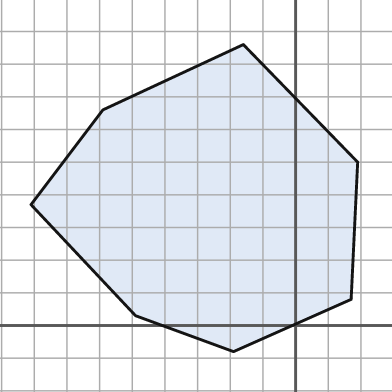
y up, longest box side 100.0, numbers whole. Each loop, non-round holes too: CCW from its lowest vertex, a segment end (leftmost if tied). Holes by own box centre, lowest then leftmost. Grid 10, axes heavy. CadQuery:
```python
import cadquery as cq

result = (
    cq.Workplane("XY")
    .moveTo(-19.0, -8.0)
    .lineTo(17.0, 8.0)
    .lineTo(19.0, 50.0)
    .lineTo(-16.0, 86.0)
    .lineTo(-59.0, 66.0)
    .lineTo(-81.0, 37.0)
    .lineTo(-49.0, 3.0)
    .close()
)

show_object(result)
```